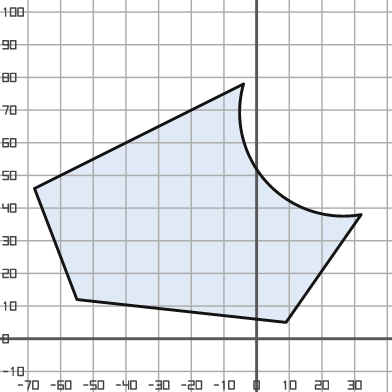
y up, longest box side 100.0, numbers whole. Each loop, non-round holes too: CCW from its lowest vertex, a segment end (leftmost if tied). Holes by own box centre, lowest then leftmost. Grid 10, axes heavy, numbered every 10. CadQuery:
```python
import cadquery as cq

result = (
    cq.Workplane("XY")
    .moveTo(9.0, 5.0)
    .lineTo(32.0, 38.0)
    .threePointArc((3.0, 48.0), (-4.0, 78.0))
    .lineTo(-68.0, 46.0)
    .lineTo(-55.0, 12.0)
    .close()
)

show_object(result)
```